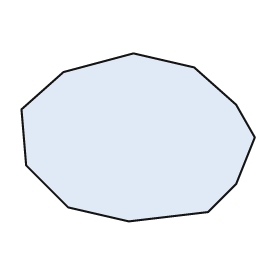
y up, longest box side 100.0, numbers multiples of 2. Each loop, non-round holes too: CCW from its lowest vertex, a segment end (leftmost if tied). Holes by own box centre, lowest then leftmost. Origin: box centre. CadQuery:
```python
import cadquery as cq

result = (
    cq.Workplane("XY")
    .moveTo(-4.0, -36.0)
    .lineTo(30.0, -32.0)
    .lineTo(42.0, -20.0)
    .lineTo(50.0, 0.0)
    .lineTo(42.0, 14.0)
    .lineTo(24.0, 30.0)
    .lineTo(-2.0, 36.0)
    .lineTo(-32.0, 28.0)
    .lineTo(-50.0, 12.0)
    .lineTo(-48.0, -12.0)
    .lineTo(-30.0, -30.0)
    .close()
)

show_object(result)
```